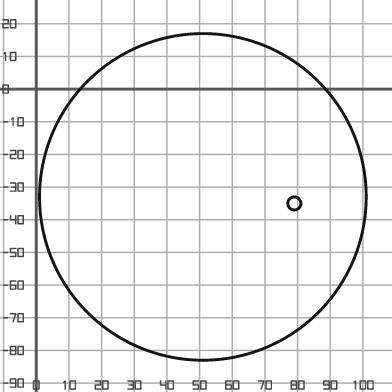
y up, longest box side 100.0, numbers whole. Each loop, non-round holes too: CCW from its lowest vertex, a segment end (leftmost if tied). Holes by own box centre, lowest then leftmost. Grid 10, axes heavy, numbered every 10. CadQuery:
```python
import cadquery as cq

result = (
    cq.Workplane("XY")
    .moveTo(51.0, -33.0)
    .circle(50.0)
    .moveTo(79.0, -35.0)
    .circle(2.0)
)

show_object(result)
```